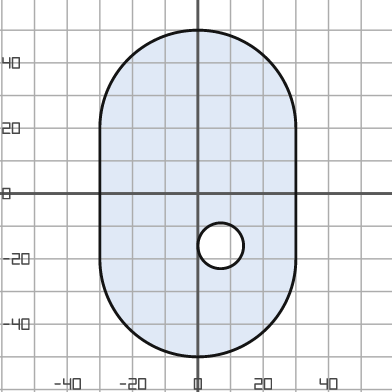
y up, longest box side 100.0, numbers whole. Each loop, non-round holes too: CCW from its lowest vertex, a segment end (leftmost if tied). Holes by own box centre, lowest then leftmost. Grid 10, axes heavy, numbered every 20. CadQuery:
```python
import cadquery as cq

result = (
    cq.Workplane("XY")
    .moveTo(-30.0, -20.0)
    .threePointArc((0.0, -50.0), (30.0, -20.0))
    .lineTo(30.0, 20.0)
    .threePointArc((0.0, 50.0), (-30.0, 20.0))
    .close()
    .moveTo(7.0, -16.0)
    .circle(7.0)
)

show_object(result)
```